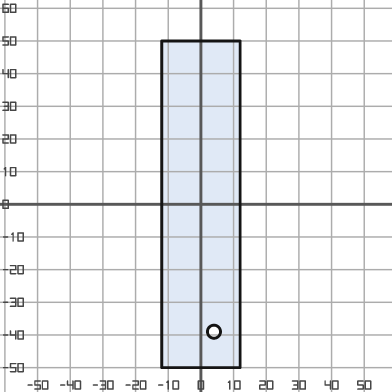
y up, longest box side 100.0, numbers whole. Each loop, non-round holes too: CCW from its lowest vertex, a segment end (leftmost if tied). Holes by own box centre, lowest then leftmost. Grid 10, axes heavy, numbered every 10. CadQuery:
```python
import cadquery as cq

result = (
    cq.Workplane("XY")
    .moveTo(-12.0, -50.0)
    .lineTo(12.0, -50.0)
    .lineTo(12.0, 50.0)
    .lineTo(-12.0, 50.0)
    .close()
    .moveTo(4.0, -39.0)
    .circle(2.0)
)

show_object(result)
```